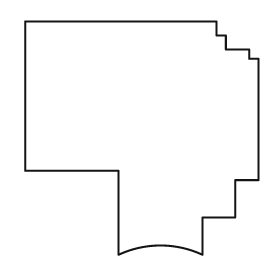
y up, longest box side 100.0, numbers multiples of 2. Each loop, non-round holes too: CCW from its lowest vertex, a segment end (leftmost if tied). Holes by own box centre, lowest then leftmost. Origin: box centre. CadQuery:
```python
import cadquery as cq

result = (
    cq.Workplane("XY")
    .moveTo(-10.0, -50.0)
    .threePointArc((8.0, -46.0), (26.0, -50.0))
    .lineTo(26.0, -34.0)
    .lineTo(40.0, -34.0)
    .lineTo(40.0, -18.0)
    .lineTo(50.0, -18.0)
    .lineTo(50.0, 34.0)
    .lineTo(46.0, 34.0)
    .lineTo(46.0, 38.0)
    .lineTo(36.0, 38.0)
    .lineTo(36.0, 44.0)
    .lineTo(32.0, 44.0)
    .lineTo(32.0, 50.0)
    .lineTo(-50.0, 50.0)
    .lineTo(-50.0, -14.0)
    .lineTo(-10.0, -14.0)
    .close()
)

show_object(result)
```